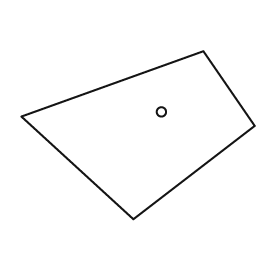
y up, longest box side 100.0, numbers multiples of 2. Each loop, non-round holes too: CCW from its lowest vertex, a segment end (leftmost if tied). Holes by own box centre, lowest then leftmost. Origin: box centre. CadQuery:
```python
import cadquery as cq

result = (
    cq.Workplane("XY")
    .moveTo(-2.0, -36.0)
    .lineTo(50.0, 4.0)
    .lineTo(28.0, 36.0)
    .lineTo(-50.0, 8.0)
    .close()
    .moveTo(10.0, 10.0)
    .circle(2.0)
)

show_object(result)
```